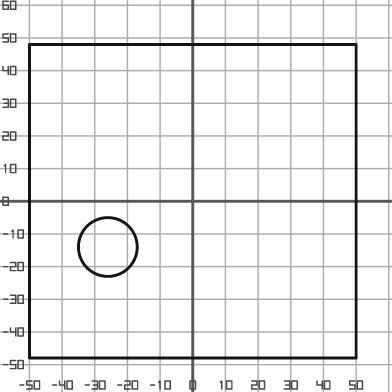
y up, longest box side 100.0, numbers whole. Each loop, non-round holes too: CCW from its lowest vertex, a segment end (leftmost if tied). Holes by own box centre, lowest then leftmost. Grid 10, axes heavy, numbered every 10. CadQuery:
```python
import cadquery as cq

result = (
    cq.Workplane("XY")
    .moveTo(-50.0, -48.0)
    .lineTo(50.0, -48.0)
    .lineTo(50.0, 48.0)
    .lineTo(-50.0, 48.0)
    .close()
    .moveTo(-26.0, -14.0)
    .circle(9.0)
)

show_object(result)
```